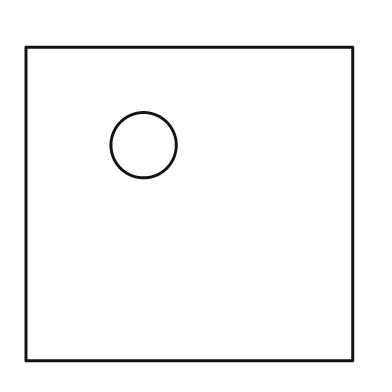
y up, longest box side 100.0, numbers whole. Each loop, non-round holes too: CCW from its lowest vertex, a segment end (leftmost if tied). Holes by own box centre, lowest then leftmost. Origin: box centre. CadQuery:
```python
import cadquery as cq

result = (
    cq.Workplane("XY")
    .moveTo(-50.0, -48.0)
    .lineTo(50.0, -48.0)
    .lineTo(50.0, 48.0)
    .lineTo(-50.0, 48.0)
    .close()
    .moveTo(-14.0, 18.0)
    .circle(10.0)
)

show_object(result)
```